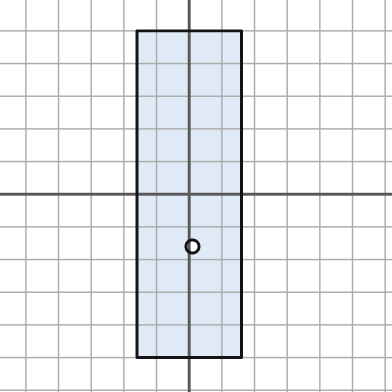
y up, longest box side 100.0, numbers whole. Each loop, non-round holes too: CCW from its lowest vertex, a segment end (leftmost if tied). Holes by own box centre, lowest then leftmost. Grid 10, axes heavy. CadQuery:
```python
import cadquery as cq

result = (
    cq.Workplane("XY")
    .moveTo(-16.0, -50.0)
    .lineTo(16.0, -50.0)
    .lineTo(16.0, 50.0)
    .lineTo(-16.0, 50.0)
    .close()
    .moveTo(1.0, -16.0)
    .circle(2.0)
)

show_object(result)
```